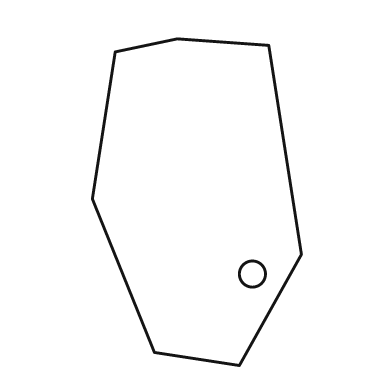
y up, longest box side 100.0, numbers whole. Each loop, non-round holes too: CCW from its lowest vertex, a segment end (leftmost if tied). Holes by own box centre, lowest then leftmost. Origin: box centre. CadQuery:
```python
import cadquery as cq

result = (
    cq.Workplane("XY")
    .moveTo(13.0, -50.0)
    .lineTo(32.0, -16.0)
    .lineTo(22.0, 48.0)
    .lineTo(-6.0, 50.0)
    .lineTo(-25.0, 46.0)
    .lineTo(-32.0, 1.0)
    .lineTo(-13.0, -46.0)
    .close()
    .moveTo(17.0, -22.0)
    .circle(4.0)
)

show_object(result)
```